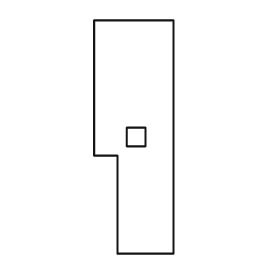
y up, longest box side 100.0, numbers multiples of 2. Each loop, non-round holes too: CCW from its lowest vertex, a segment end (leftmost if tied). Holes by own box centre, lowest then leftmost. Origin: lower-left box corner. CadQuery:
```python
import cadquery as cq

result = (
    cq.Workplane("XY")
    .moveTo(10.0, 0.0)
    .lineTo(34.0, 0.0)
    .lineTo(34.0, 100.0)
    .lineTo(0.0, 100.0)
    .lineTo(0.0, 42.0)
    .lineTo(10.0, 42.0)
    .close()
    .moveTo(14.0, 46.0)
    .lineTo(22.0, 46.0)
    .lineTo(22.0, 54.0)
    .lineTo(14.0, 54.0)
    .close()
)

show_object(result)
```